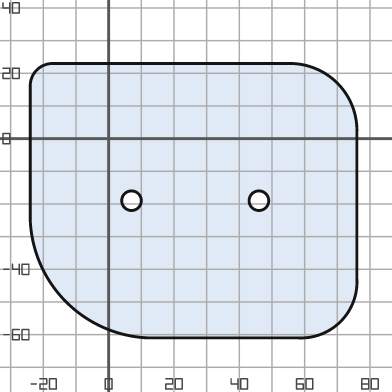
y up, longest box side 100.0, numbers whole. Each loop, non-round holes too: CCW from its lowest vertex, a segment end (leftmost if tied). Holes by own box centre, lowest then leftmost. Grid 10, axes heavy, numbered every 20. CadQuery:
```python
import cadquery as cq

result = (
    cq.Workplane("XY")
    .moveTo(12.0, -61.0)
    .lineTo(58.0, -61.0)
    .threePointArc((71.0, -56.0), (76.0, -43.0))
    .lineTo(76.0, 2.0)
    .threePointArc((70.0, 17.0), (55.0, 23.0))
    .lineTo(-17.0, 23.0)
    .threePointArc((-22.0, 21.0), (-24.0, 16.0))
    .lineTo(-24.0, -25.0)
    .threePointArc((-13.0, -50.0), (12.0, -61.0))
    .close()
    .moveTo(7.0, -19.0)
    .circle(3.0)
    .moveTo(46.0, -19.0)
    .circle(3.0)
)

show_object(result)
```